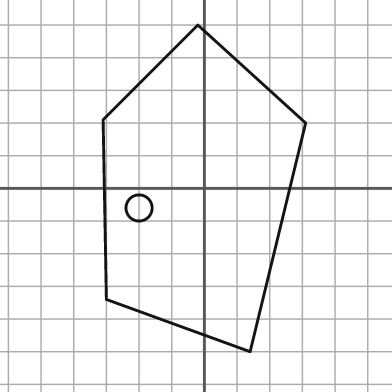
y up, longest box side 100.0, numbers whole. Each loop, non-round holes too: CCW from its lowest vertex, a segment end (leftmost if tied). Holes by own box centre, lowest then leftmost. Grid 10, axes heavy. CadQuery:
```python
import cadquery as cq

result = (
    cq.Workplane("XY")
    .moveTo(14.0, -50.0)
    .lineTo(31.0, 20.0)
    .lineTo(-2.0, 50.0)
    .lineTo(-31.0, 21.0)
    .lineTo(-30.0, -34.0)
    .close()
    .moveTo(-20.0, -6.0)
    .circle(4.0)
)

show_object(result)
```